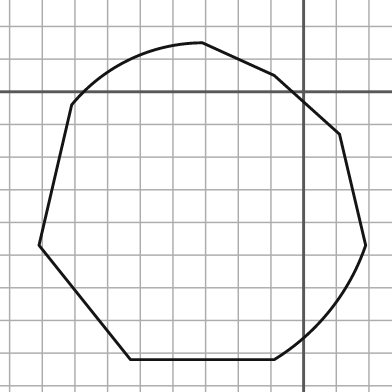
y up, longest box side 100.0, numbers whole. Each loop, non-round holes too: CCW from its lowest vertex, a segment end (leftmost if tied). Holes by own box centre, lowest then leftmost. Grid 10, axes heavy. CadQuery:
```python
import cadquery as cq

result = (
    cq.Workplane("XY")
    .moveTo(-53.0, -82.0)
    .lineTo(-9.0, -82.0)
    .threePointArc((8.0, -67.0), (19.0, -47.0))
    .lineTo(11.0, -13.0)
    .lineTo(-9.0, 5.0)
    .lineTo(-31.0, 15.0)
    .threePointArc((-53.0, 10.0), (-71.0, -4.0))
    .lineTo(-81.0, -47.0)
    .close()
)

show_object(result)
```